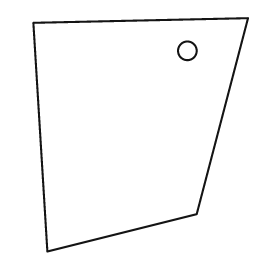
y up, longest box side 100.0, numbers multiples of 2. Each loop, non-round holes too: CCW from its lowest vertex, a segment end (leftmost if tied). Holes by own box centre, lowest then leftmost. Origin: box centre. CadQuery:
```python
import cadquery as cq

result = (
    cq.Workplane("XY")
    .moveTo(-40.0, -50.0)
    .lineTo(24.0, -34.0)
    .lineTo(46.0, 50.0)
    .lineTo(-46.0, 48.0)
    .close()
    .moveTo(20.0, 36.0)
    .circle(4.0)
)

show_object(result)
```